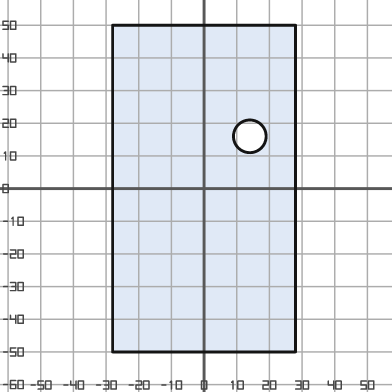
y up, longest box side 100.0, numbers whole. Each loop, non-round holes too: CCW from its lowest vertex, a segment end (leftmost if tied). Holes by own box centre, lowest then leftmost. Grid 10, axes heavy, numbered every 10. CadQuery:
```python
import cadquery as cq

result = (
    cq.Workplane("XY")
    .moveTo(-28.0, -50.0)
    .lineTo(28.0, -50.0)
    .lineTo(28.0, 50.0)
    .lineTo(-28.0, 50.0)
    .close()
    .moveTo(14.0, 16.0)
    .circle(5.0)
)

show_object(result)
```